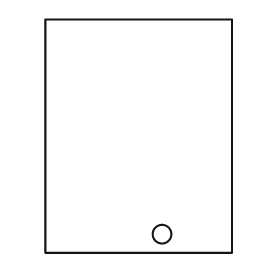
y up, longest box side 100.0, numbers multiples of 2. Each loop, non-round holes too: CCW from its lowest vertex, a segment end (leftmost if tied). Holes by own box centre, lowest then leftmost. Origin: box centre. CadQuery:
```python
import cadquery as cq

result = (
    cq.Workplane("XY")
    .moveTo(-40.0, -50.0)
    .lineTo(40.0, -50.0)
    .lineTo(40.0, 50.0)
    .lineTo(-40.0, 50.0)
    .close()
    .moveTo(10.0, -42.0)
    .circle(4.0)
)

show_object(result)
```